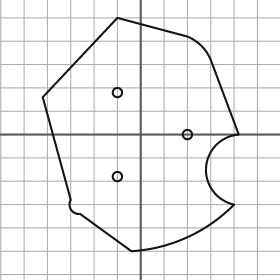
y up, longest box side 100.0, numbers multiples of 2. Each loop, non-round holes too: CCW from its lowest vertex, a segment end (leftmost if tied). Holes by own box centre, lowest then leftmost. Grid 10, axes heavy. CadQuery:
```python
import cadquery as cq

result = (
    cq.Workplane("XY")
    .moveTo(-4.0, -50.0)
    .threePointArc((20.0, -44.0), (40.0, -30.0))
    .threePointArc((28.0, -14.0), (42.0, 0.0))
    .lineTo(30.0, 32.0)
    .threePointArc((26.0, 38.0), (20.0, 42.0))
    .lineTo(-10.0, 50.0)
    .lineTo(-42.0, 16.0)
    .lineTo(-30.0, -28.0)
    .threePointArc((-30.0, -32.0), (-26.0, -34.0))
    .close()
    .moveTo(-10.0, -18.0)
    .circle(2.0)
    .moveTo(20.0, 0.0)
    .circle(2.0)
    .moveTo(-10.0, 18.0)
    .circle(2.0)
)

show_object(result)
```